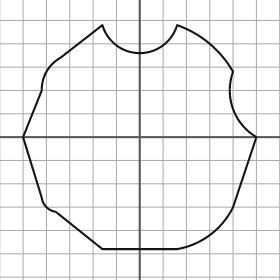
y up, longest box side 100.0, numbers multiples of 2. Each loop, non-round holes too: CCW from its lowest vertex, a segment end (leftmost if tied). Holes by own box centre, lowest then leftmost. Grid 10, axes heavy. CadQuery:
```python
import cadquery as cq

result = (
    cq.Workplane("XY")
    .moveTo(-16.0, -48.0)
    .lineTo(16.0, -48.0)
    .threePointArc((30.0, -42.0), (40.0, -30.0))
    .lineTo(50.0, 0.0)
    .threePointArc((40.0, 12.0), (40.0, 28.0))
    .threePointArc((30.0, 40.0), (16.0, 48.0))
    .threePointArc((0.0, 36.0), (-16.0, 48.0))
    .lineTo(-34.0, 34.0)
    .threePointArc((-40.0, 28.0), (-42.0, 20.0))
    .lineTo(-50.0, 0.0)
    .lineTo(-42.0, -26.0)
    .threePointArc((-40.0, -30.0), (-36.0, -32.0))
    .close()
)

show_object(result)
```